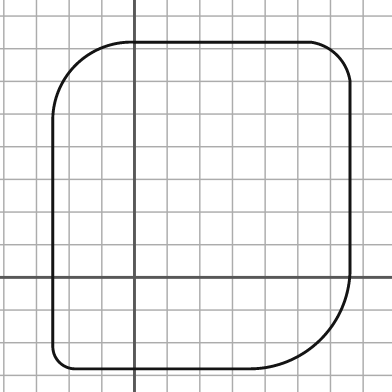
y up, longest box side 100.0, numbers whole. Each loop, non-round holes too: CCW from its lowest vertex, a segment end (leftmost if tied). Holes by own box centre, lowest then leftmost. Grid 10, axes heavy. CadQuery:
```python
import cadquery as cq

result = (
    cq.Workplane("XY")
    .moveTo(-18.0, -28.0)
    .lineTo(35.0, -28.0)
    .threePointArc((57.0, -19.0), (66.0, 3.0))
    .lineTo(66.0, 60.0)
    .threePointArc((62.0, 68.0), (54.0, 72.0))
    .lineTo(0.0, 72.0)
    .threePointArc((-18.0, 65.0), (-25.0, 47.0))
    .lineTo(-25.0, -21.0)
    .threePointArc((-23.0, -26.0), (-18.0, -28.0))
    .close()
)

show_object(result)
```